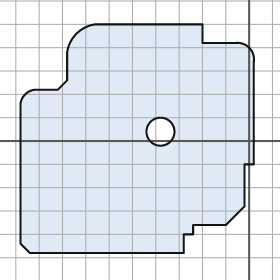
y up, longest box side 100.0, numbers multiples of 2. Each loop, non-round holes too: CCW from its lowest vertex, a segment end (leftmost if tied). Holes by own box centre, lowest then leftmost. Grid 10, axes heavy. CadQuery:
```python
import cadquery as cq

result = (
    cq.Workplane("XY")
    .moveTo(-94.0, -48.0)
    .lineTo(-28.0, -48.0)
    .lineTo(-28.0, -40.0)
    .lineTo(-24.0, -40.0)
    .lineTo(-24.0, -36.0)
    .lineTo(-10.0, -36.0)
    .lineTo(-2.0, -28.0)
    .lineTo(-2.0, -10.0)
    .lineTo(2.0, -10.0)
    .lineTo(2.0, 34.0)
    .threePointArc((0.0, 40.0), (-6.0, 42.0))
    .lineTo(-20.0, 42.0)
    .lineTo(-20.0, 50.0)
    .lineTo(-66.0, 50.0)
    .threePointArc((-74.0, 46.0), (-78.0, 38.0))
    .lineTo(-78.0, 26.0)
    .lineTo(-82.0, 22.0)
    .lineTo(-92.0, 22.0)
    .threePointArc((-96.0, 20.0), (-98.0, 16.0))
    .lineTo(-98.0, -44.0)
    .close()
    .moveTo(-38.0, 4.0)
    .circle(6.0)
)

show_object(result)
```